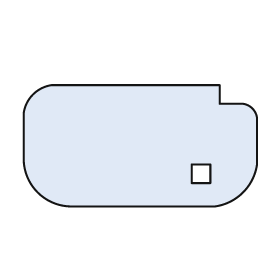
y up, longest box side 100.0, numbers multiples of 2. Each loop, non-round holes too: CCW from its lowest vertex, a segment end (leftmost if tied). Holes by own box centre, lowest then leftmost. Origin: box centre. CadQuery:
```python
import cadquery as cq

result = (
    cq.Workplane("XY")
    .moveTo(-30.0, -26.0)
    .lineTo(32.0, -26.0)
    .threePointArc((44.0, -20.0), (50.0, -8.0))
    .lineTo(50.0, 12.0)
    .threePointArc((48.0, 16.0), (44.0, 18.0))
    .lineTo(34.0, 18.0)
    .lineTo(34.0, 26.0)
    .lineTo(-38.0, 26.0)
    .threePointArc((-46.0, 22.0), (-50.0, 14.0))
    .lineTo(-50.0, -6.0)
    .threePointArc((-44.0, -20.0), (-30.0, -26.0))
    .close()
    .moveTo(22.0, -16.0)
    .lineTo(30.0, -16.0)
    .lineTo(30.0, -8.0)
    .lineTo(22.0, -8.0)
    .close()
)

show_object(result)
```